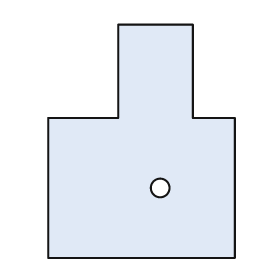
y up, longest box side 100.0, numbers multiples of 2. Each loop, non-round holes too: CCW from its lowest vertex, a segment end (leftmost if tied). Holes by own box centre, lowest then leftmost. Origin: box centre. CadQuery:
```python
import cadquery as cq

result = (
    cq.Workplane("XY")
    .moveTo(-40.0, -50.0)
    .lineTo(40.0, -50.0)
    .lineTo(40.0, 10.0)
    .lineTo(22.0, 10.0)
    .lineTo(22.0, 50.0)
    .lineTo(-10.0, 50.0)
    .lineTo(-10.0, 10.0)
    .lineTo(-40.0, 10.0)
    .close()
    .moveTo(8.0, -20.0)
    .circle(4.0)
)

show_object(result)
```